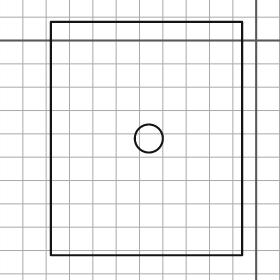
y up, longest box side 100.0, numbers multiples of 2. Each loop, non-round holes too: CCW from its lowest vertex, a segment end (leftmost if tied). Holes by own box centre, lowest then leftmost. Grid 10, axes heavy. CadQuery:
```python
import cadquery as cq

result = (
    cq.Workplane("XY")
    .moveTo(-88.0, -92.0)
    .lineTo(-6.0, -92.0)
    .lineTo(-6.0, 8.0)
    .lineTo(-88.0, 8.0)
    .close()
    .moveTo(-46.0, -42.0)
    .circle(6.0)
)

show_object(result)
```